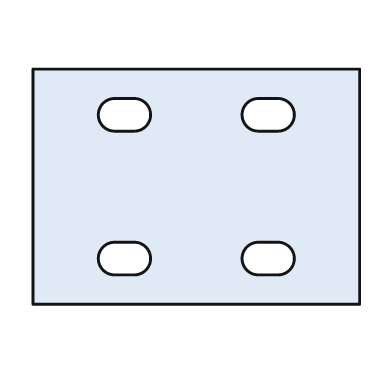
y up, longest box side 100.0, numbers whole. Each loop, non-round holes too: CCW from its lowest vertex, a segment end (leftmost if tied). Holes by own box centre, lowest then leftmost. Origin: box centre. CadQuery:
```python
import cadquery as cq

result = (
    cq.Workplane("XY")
    .moveTo(-50.0, -36.0)
    .lineTo(50.0, -36.0)
    .lineTo(50.0, 36.0)
    .lineTo(-50.0, 36.0)
    .close()
    .moveTo(-25.0, -27.0)
    .lineTo(-19.0, -27.0)
    .threePointArc((-14.0, -22.0), (-19.0, -17.0))
    .lineTo(-25.0, -17.0)
    .threePointArc((-30.0, -22.0), (-25.0, -27.0))
    .close()
    .moveTo(19.0, -27.0)
    .lineTo(25.0, -27.0)
    .threePointArc((30.0, -22.0), (25.0, -17.0))
    .lineTo(19.0, -17.0)
    .threePointArc((14.0, -22.0), (19.0, -27.0))
    .close()
    .moveTo(-25.0, 17.0)
    .lineTo(-19.0, 17.0)
    .threePointArc((-14.0, 22.0), (-19.0, 27.0))
    .lineTo(-25.0, 27.0)
    .threePointArc((-30.0, 22.0), (-25.0, 17.0))
    .close()
    .moveTo(19.0, 17.0)
    .lineTo(25.0, 17.0)
    .threePointArc((30.0, 22.0), (25.0, 27.0))
    .lineTo(19.0, 27.0)
    .threePointArc((14.0, 22.0), (19.0, 17.0))
    .close()
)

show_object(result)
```